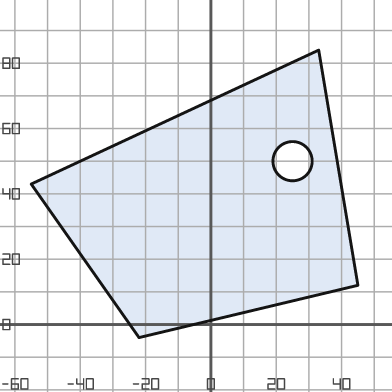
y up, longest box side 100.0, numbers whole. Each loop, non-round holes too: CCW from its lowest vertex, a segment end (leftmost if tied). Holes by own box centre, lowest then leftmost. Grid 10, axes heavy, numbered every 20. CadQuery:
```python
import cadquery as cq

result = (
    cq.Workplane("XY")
    .moveTo(-22.0, -4.0)
    .lineTo(45.0, 12.0)
    .lineTo(33.0, 84.0)
    .lineTo(-55.0, 43.0)
    .close()
    .moveTo(25.0, 50.0)
    .circle(6.0)
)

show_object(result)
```